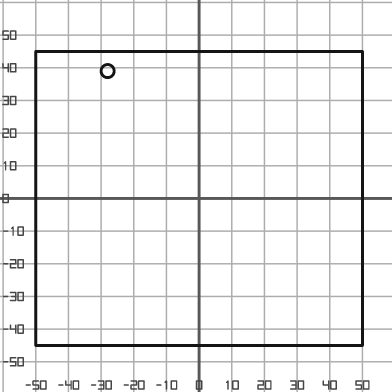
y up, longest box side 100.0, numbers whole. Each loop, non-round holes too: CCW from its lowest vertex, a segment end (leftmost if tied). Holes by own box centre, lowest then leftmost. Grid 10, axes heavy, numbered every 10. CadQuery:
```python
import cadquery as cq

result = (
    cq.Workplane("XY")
    .moveTo(-50.0, -45.0)
    .lineTo(50.0, -45.0)
    .lineTo(50.0, 45.0)
    .lineTo(-50.0, 45.0)
    .close()
    .moveTo(-28.0, 39.0)
    .circle(2.0)
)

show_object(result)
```